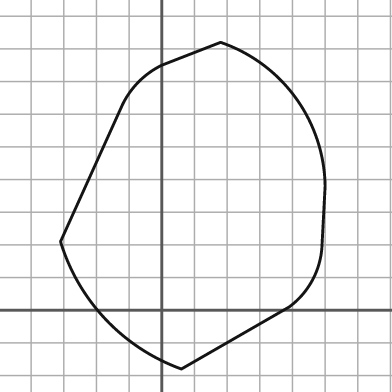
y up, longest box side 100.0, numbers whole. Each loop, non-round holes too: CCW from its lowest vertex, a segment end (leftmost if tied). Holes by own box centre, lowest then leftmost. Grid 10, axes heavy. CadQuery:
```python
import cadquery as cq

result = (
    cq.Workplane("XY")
    .moveTo(6.0, -18.0)
    .lineTo(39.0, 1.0)
    .threePointArc((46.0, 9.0), (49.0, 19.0))
    .lineTo(50.0, 38.0)
    .threePointArc((41.0, 65.0), (18.0, 82.0))
    .lineTo(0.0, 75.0)
    .threePointArc((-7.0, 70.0), (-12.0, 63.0))
    .lineTo(-31.0, 21.0)
    .threePointArc((-17.0, -3.0), (6.0, -18.0))
    .close()
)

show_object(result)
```